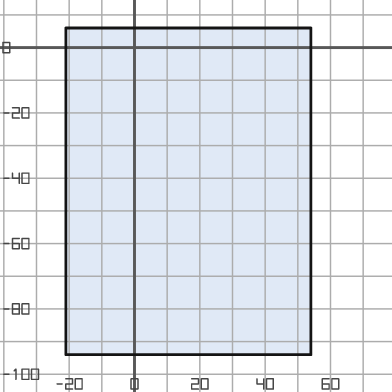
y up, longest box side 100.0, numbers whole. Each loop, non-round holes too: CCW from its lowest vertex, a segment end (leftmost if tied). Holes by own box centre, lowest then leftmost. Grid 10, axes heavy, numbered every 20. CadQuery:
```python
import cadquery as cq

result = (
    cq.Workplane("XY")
    .moveTo(-21.0, -94.0)
    .lineTo(54.0, -94.0)
    .lineTo(54.0, 6.0)
    .lineTo(-21.0, 6.0)
    .close()
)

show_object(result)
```